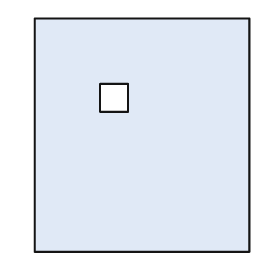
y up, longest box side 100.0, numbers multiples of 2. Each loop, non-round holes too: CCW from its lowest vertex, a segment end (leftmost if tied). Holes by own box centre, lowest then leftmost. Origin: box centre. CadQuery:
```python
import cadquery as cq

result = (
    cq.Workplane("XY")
    .moveTo(-46.0, -50.0)
    .lineTo(46.0, -50.0)
    .lineTo(46.0, 50.0)
    .lineTo(-46.0, 50.0)
    .close()
    .moveTo(-18.0, 10.0)
    .lineTo(-6.0, 10.0)
    .lineTo(-6.0, 22.0)
    .lineTo(-18.0, 22.0)
    .close()
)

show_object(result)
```